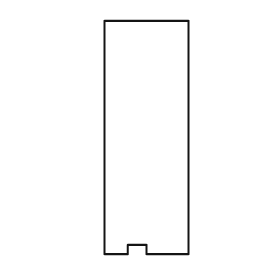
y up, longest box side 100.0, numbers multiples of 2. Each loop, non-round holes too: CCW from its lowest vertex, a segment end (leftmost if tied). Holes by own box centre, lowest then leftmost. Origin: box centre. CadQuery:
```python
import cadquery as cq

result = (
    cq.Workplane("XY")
    .moveTo(-18.0, -50.0)
    .lineTo(-8.0, -50.0)
    .lineTo(-8.0, -46.0)
    .lineTo(0.0, -46.0)
    .lineTo(0.0, -50.0)
    .lineTo(18.0, -50.0)
    .lineTo(18.0, 50.0)
    .lineTo(-18.0, 50.0)
    .close()
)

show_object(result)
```